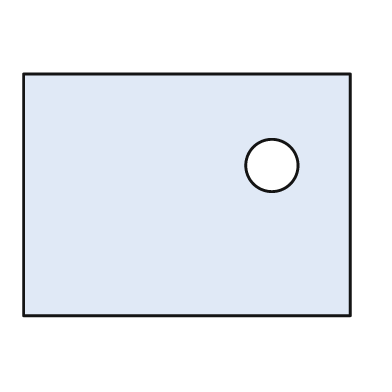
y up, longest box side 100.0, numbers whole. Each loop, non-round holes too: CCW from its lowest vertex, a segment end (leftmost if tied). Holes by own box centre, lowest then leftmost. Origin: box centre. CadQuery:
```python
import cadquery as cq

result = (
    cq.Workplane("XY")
    .moveTo(-50.0, -37.0)
    .lineTo(50.0, -37.0)
    .lineTo(50.0, 37.0)
    .lineTo(-50.0, 37.0)
    .close()
    .moveTo(26.0, 9.0)
    .circle(8.0)
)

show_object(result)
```